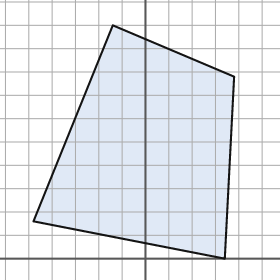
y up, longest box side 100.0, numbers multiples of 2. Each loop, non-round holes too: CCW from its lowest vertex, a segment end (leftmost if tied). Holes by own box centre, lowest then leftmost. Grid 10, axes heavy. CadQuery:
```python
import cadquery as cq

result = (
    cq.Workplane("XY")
    .moveTo(34.0, 0.0)
    .lineTo(38.0, 78.0)
    .lineTo(-14.0, 100.0)
    .lineTo(-48.0, 16.0)
    .close()
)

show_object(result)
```